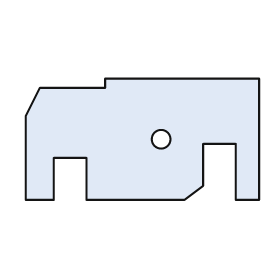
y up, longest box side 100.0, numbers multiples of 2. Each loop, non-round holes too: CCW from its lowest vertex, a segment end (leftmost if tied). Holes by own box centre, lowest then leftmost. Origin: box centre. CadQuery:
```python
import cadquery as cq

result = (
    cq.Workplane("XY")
    .moveTo(-50.0, -26.0)
    .lineTo(-38.0, -26.0)
    .lineTo(-38.0, -8.0)
    .lineTo(-24.0, -8.0)
    .lineTo(-24.0, -26.0)
    .lineTo(18.0, -26.0)
    .lineTo(26.0, -20.0)
    .lineTo(26.0, -2.0)
    .lineTo(40.0, -2.0)
    .lineTo(40.0, -26.0)
    .lineTo(50.0, -26.0)
    .lineTo(50.0, 26.0)
    .lineTo(-16.0, 26.0)
    .lineTo(-16.0, 22.0)
    .lineTo(-44.0, 22.0)
    .lineTo(-50.0, 10.0)
    .close()
    .moveTo(8.0, 0.0)
    .circle(4.0)
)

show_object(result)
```